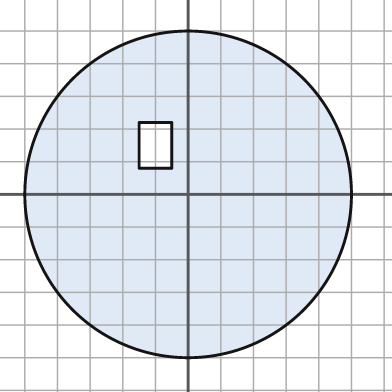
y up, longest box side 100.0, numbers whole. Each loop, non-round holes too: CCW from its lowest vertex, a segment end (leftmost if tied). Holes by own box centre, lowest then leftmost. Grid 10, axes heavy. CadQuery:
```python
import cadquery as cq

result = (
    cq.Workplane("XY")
    .moveTo(0.0, 0.0)
    .circle(50.0)
    .moveTo(-15.0, 8.0)
    .lineTo(-5.0, 8.0)
    .lineTo(-5.0, 22.0)
    .lineTo(-15.0, 22.0)
    .close()
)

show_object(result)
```